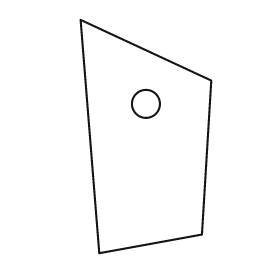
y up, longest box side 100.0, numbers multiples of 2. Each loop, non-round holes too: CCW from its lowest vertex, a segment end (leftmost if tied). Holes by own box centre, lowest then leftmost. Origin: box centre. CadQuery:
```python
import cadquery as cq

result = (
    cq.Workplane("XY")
    .moveTo(-20.0, -50.0)
    .lineTo(24.0, -42.0)
    .lineTo(28.0, 24.0)
    .lineTo(-28.0, 50.0)
    .close()
    .moveTo(0.0, 14.0)
    .circle(6.0)
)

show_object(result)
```